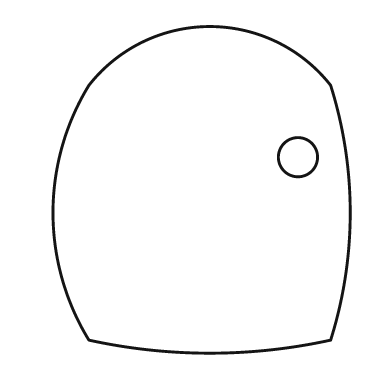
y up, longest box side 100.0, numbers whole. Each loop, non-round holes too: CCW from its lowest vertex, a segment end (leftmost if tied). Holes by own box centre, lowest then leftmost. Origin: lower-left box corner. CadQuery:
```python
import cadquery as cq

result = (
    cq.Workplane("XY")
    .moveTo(11.0, 4.0)
    .threePointArc((48.0, 0.0), (85.0, 4.0))
    .threePointArc((91.0, 43.0), (85.0, 82.0))
    .threePointArc((48.0, 100.0), (11.0, 82.0))
    .threePointArc((0.0, 43.0), (11.0, 4.0))
    .close()
    .moveTo(75.0, 60.0)
    .circle(6.0)
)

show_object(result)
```